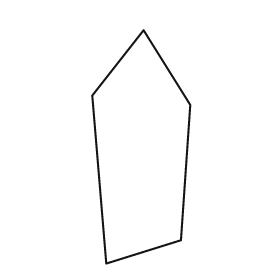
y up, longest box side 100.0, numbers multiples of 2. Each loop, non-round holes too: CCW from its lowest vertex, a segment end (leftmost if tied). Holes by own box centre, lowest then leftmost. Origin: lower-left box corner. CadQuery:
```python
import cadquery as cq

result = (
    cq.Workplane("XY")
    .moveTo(6.0, 0.0)
    .lineTo(38.0, 10.0)
    .lineTo(42.0, 68.0)
    .lineTo(22.0, 100.0)
    .lineTo(0.0, 72.0)
    .close()
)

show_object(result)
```